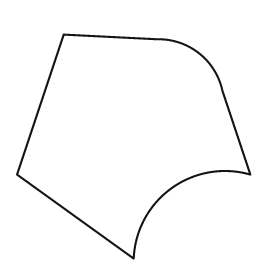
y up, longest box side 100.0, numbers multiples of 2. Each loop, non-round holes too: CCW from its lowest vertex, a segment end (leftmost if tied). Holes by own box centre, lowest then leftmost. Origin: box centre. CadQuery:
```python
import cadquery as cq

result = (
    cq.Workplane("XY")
    .moveTo(0.0, -48.0)
    .threePointArc((16.0, -18.0), (50.0, -12.0))
    .lineTo(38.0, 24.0)
    .threePointArc((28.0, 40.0), (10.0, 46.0))
    .lineTo(-30.0, 48.0)
    .lineTo(-50.0, -12.0)
    .close()
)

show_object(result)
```